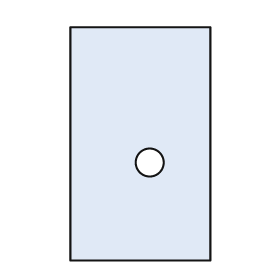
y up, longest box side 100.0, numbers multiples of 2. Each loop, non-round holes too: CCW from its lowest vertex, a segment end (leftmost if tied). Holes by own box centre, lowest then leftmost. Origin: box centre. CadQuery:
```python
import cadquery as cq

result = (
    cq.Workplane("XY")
    .moveTo(-30.0, -50.0)
    .lineTo(30.0, -50.0)
    .lineTo(30.0, 50.0)
    .lineTo(-30.0, 50.0)
    .close()
    .moveTo(4.0, -8.0)
    .circle(6.0)
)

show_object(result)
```